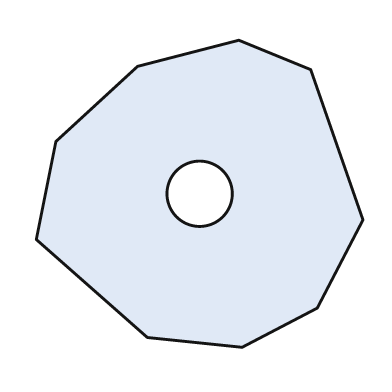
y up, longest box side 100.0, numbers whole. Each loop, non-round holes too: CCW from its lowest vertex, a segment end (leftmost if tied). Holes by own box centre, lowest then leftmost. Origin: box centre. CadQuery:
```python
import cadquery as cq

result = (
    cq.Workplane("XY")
    .moveTo(13.0, -47.0)
    .lineTo(36.0, -35.0)
    .lineTo(50.0, -8.0)
    .lineTo(34.0, 38.0)
    .lineTo(12.0, 47.0)
    .lineTo(-19.0, 39.0)
    .lineTo(-44.0, 16.0)
    .lineTo(-50.0, -14.0)
    .lineTo(-16.0, -44.0)
    .close()
    .moveTo(0.0, 0.0)
    .circle(10.0)
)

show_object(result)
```